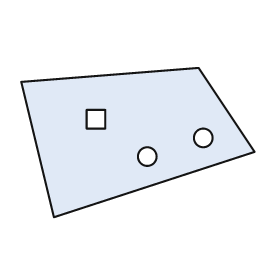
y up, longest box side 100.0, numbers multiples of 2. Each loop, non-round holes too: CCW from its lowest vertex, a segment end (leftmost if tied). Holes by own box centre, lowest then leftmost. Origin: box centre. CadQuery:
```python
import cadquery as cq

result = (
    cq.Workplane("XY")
    .moveTo(-36.0, -32.0)
    .lineTo(50.0, -4.0)
    .lineTo(26.0, 32.0)
    .lineTo(-50.0, 26.0)
    .close()
    .moveTo(4.0, -6.0)
    .circle(4.0)
    .moveTo(28.0, 2.0)
    .circle(4.0)
    .moveTo(-22.0, 6.0)
    .lineTo(-14.0, 6.0)
    .lineTo(-14.0, 14.0)
    .lineTo(-22.0, 14.0)
    .close()
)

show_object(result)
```